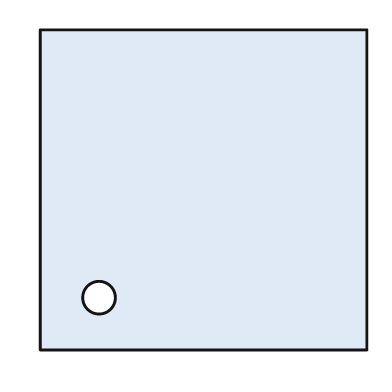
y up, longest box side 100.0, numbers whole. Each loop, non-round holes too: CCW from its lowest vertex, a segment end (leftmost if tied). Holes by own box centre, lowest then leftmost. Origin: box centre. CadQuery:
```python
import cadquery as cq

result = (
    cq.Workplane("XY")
    .moveTo(-50.0, -49.0)
    .lineTo(50.0, -49.0)
    .lineTo(50.0, 49.0)
    .lineTo(-50.0, 49.0)
    .close()
    .moveTo(-32.0, -33.0)
    .circle(5.0)
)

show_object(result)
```